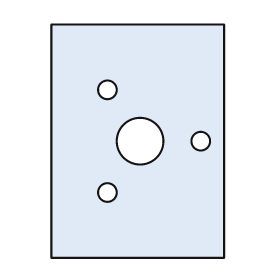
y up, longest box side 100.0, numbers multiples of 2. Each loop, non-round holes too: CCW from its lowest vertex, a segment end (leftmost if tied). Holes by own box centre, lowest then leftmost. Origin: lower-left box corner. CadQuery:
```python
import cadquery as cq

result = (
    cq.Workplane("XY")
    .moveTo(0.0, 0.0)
    .lineTo(74.0, 0.0)
    .lineTo(74.0, 100.0)
    .lineTo(0.0, 100.0)
    .close()
    .moveTo(24.0, 28.0)
    .circle(4.0)
    .moveTo(38.0, 50.0)
    .circle(10.0)
    .moveTo(64.0, 50.0)
    .circle(4.0)
    .moveTo(24.0, 72.0)
    .circle(4.0)
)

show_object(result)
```